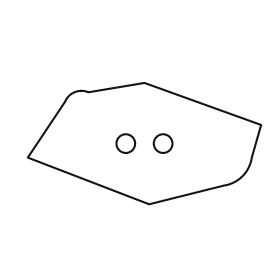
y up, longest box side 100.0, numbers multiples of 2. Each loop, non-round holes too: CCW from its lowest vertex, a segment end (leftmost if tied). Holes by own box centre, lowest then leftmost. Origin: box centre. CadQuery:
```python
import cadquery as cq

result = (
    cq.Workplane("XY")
    .moveTo(2.0, -26.0)
    .lineTo(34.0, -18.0)
    .threePointArc((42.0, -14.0), (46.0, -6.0))
    .lineTo(50.0, 8.0)
    .lineTo(0.0, 26.0)
    .lineTo(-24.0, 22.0)
    .threePointArc((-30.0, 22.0), (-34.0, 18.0))
    .lineTo(-50.0, -6.0)
    .close()
    .moveTo(-8.0, 0.0)
    .circle(4.0)
    .moveTo(8.0, 0.0)
    .circle(4.0)
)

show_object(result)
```